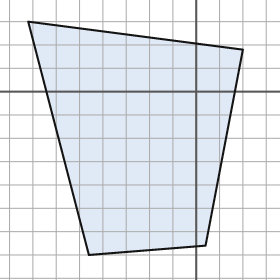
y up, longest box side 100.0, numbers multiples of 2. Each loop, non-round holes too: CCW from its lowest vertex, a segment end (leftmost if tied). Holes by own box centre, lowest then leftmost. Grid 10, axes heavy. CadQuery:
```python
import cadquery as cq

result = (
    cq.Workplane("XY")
    .moveTo(-46.0, -70.0)
    .lineTo(4.0, -66.0)
    .lineTo(20.0, 18.0)
    .lineTo(-72.0, 30.0)
    .close()
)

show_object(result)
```